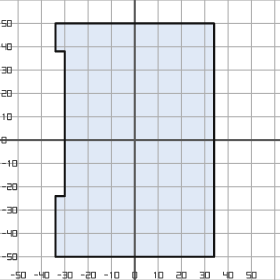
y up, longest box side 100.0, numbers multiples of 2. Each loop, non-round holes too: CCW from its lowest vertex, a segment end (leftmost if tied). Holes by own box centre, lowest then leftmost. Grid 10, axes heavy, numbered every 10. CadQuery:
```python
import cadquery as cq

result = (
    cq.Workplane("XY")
    .moveTo(-34.0, -50.0)
    .lineTo(34.0, -50.0)
    .lineTo(34.0, 50.0)
    .lineTo(-34.0, 50.0)
    .lineTo(-34.0, 38.0)
    .lineTo(-30.0, 38.0)
    .lineTo(-30.0, -24.0)
    .lineTo(-34.0, -24.0)
    .close()
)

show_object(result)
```